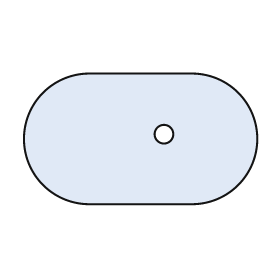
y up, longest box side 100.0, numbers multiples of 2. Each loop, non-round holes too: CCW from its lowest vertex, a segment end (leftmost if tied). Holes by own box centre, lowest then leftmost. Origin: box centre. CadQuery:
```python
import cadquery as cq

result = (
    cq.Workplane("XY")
    .moveTo(-22.0, -28.0)
    .lineTo(22.0, -28.0)
    .threePointArc((50.0, 0.0), (22.0, 28.0))
    .lineTo(-22.0, 28.0)
    .threePointArc((-50.0, 0.0), (-22.0, -28.0))
    .close()
    .moveTo(10.0, 2.0)
    .circle(4.0)
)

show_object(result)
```